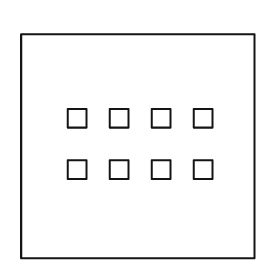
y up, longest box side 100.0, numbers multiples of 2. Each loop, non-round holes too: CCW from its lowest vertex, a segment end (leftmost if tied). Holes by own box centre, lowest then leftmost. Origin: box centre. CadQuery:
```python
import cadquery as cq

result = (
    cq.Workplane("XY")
    .moveTo(-50.0, -48.0)
    .lineTo(50.0, -48.0)
    .lineTo(50.0, 48.0)
    .lineTo(-50.0, 48.0)
    .close()
    .moveTo(-30.0, -14.0)
    .lineTo(-22.0, -14.0)
    .lineTo(-22.0, -6.0)
    .lineTo(-30.0, -6.0)
    .close()
    .moveTo(-12.0, -14.0)
    .lineTo(-4.0, -14.0)
    .lineTo(-4.0, -6.0)
    .lineTo(-12.0, -6.0)
    .close()
    .moveTo(6.0, -14.0)
    .lineTo(14.0, -14.0)
    .lineTo(14.0, -6.0)
    .lineTo(6.0, -6.0)
    .close()
    .moveTo(24.0, -14.0)
    .lineTo(32.0, -14.0)
    .lineTo(32.0, -6.0)
    .lineTo(24.0, -6.0)
    .close()
    .moveTo(-30.0, 8.0)
    .lineTo(-22.0, 8.0)
    .lineTo(-22.0, 16.0)
    .lineTo(-30.0, 16.0)
    .close()
    .moveTo(-12.0, 8.0)
    .lineTo(-4.0, 8.0)
    .lineTo(-4.0, 16.0)
    .lineTo(-12.0, 16.0)
    .close()
    .moveTo(6.0, 8.0)
    .lineTo(14.0, 8.0)
    .lineTo(14.0, 16.0)
    .lineTo(6.0, 16.0)
    .close()
    .moveTo(24.0, 8.0)
    .lineTo(32.0, 8.0)
    .lineTo(32.0, 16.0)
    .lineTo(24.0, 16.0)
    .close()
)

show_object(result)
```